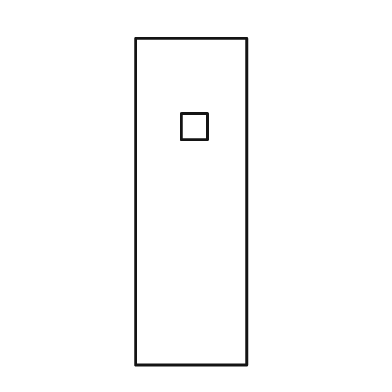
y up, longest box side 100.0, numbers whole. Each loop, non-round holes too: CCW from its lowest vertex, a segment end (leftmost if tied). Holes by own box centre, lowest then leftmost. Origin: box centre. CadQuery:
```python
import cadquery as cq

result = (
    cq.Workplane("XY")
    .moveTo(-17.0, -50.0)
    .lineTo(17.0, -50.0)
    .lineTo(17.0, 50.0)
    .lineTo(-17.0, 50.0)
    .close()
    .moveTo(-3.0, 19.0)
    .lineTo(5.0, 19.0)
    .lineTo(5.0, 27.0)
    .lineTo(-3.0, 27.0)
    .close()
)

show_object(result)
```